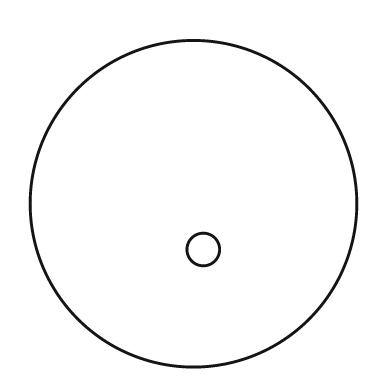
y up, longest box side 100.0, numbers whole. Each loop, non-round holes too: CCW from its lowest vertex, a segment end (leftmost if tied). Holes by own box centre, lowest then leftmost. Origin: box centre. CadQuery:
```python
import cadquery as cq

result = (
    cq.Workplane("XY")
    .moveTo(0.0, 0.0)
    .circle(50.0)
    .moveTo(3.0, -14.0)
    .circle(5.0)
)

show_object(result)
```